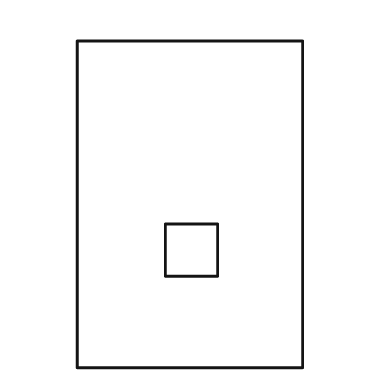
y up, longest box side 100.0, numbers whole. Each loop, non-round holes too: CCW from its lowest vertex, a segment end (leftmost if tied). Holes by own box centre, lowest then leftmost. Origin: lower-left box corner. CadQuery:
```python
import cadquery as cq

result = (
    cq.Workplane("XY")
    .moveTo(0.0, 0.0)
    .lineTo(69.0, 0.0)
    .lineTo(69.0, 100.0)
    .lineTo(0.0, 100.0)
    .close()
    .moveTo(27.0, 28.0)
    .lineTo(43.0, 28.0)
    .lineTo(43.0, 44.0)
    .lineTo(27.0, 44.0)
    .close()
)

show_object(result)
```